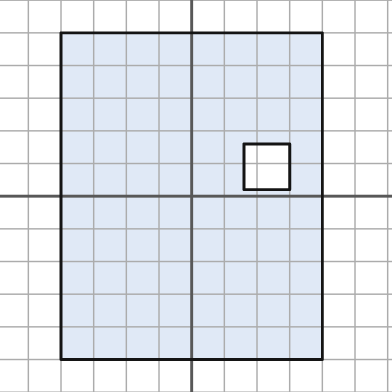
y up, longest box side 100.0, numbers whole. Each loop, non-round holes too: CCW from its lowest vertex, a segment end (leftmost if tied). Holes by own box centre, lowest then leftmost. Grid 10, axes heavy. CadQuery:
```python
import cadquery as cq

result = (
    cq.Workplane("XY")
    .moveTo(-40.0, -50.0)
    .lineTo(40.0, -50.0)
    .lineTo(40.0, 50.0)
    .lineTo(-40.0, 50.0)
    .close()
    .moveTo(16.0, 2.0)
    .lineTo(30.0, 2.0)
    .lineTo(30.0, 16.0)
    .lineTo(16.0, 16.0)
    .close()
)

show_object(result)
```